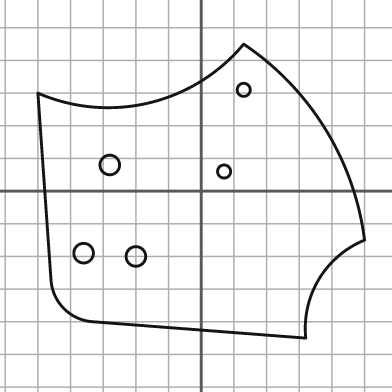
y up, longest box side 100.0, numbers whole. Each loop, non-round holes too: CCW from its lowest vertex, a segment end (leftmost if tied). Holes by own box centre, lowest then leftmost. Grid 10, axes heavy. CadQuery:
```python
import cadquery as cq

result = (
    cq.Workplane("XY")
    .moveTo(32.0, -45.0)
    .threePointArc((36.0, -27.0), (50.0, -15.0))
    .threePointArc((38.0, 19.0), (13.0, 45.0))
    .threePointArc((-16.0, 27.0), (-50.0, 30.0))
    .lineTo(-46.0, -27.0)
    .threePointArc((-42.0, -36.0), (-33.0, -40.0))
    .close()
    .moveTo(-20.0, -20.0)
    .circle(3.0)
    .moveTo(-36.0, -19.0)
    .circle(3.0)
    .moveTo(7.0, 6.0)
    .circle(2.0)
    .moveTo(-28.0, 8.0)
    .circle(3.0)
    .moveTo(13.0, 31.0)
    .circle(2.0)
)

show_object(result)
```